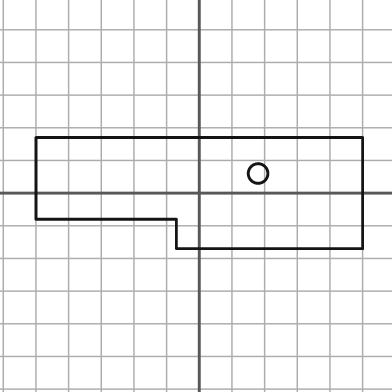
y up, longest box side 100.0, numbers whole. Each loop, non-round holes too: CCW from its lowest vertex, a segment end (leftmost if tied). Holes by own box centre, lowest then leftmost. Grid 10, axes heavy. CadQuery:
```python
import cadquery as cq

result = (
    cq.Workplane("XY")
    .moveTo(-7.0, -17.0)
    .lineTo(50.0, -17.0)
    .lineTo(50.0, 17.0)
    .lineTo(-50.0, 17.0)
    .lineTo(-50.0, -8.0)
    .lineTo(-7.0, -8.0)
    .close()
    .moveTo(18.0, 6.0)
    .circle(3.0)
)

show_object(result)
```